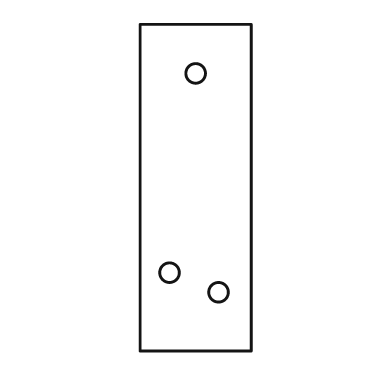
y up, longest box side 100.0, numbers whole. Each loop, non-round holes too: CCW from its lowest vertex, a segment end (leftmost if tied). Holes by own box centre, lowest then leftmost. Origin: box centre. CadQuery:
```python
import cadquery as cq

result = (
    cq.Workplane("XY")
    .moveTo(-17.0, -50.0)
    .lineTo(17.0, -50.0)
    .lineTo(17.0, 50.0)
    .lineTo(-17.0, 50.0)
    .close()
    .moveTo(7.0, -32.0)
    .circle(3.0)
    .moveTo(-8.0, -26.0)
    .circle(3.0)
    .moveTo(0.0, 35.0)
    .circle(3.0)
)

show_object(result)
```